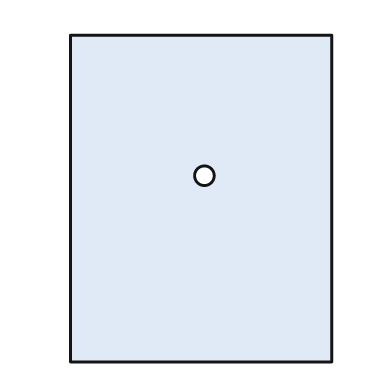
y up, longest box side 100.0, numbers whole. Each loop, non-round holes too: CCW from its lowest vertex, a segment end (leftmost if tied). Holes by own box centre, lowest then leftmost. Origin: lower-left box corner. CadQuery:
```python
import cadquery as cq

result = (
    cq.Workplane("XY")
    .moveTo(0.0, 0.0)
    .lineTo(80.0, 0.0)
    .lineTo(80.0, 100.0)
    .lineTo(0.0, 100.0)
    .close()
    .moveTo(41.0, 57.0)
    .circle(3.0)
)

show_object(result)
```